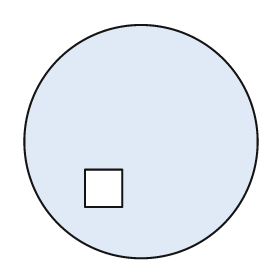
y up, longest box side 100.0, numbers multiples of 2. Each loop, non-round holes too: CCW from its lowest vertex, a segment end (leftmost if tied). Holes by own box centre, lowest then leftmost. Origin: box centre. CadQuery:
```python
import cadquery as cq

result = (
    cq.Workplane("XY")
    .moveTo(0.0, 0.0)
    .circle(50.0)
    .moveTo(-24.0, -28.0)
    .lineTo(-8.0, -28.0)
    .lineTo(-8.0, -12.0)
    .lineTo(-24.0, -12.0)
    .close()
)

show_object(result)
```